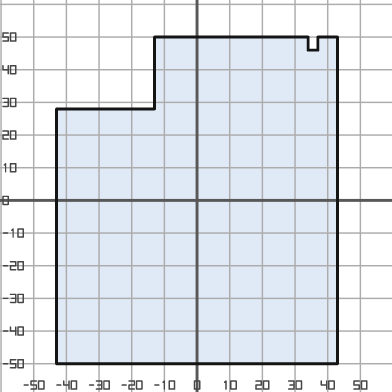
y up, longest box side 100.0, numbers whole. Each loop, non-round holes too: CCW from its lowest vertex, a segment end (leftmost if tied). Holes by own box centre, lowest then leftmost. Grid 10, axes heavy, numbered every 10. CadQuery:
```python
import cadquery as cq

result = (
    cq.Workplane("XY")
    .moveTo(-43.0, -50.0)
    .lineTo(43.0, -50.0)
    .lineTo(43.0, 50.0)
    .lineTo(37.0, 50.0)
    .lineTo(37.0, 46.0)
    .lineTo(34.0, 46.0)
    .lineTo(34.0, 50.0)
    .lineTo(-13.0, 50.0)
    .lineTo(-13.0, 28.0)
    .lineTo(-43.0, 28.0)
    .close()
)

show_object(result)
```